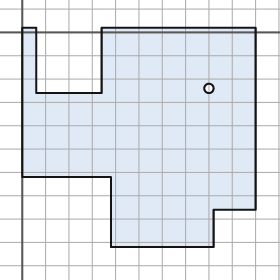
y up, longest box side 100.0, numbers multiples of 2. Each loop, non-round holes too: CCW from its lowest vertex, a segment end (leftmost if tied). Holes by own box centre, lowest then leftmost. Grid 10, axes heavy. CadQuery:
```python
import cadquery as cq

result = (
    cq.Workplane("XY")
    .moveTo(38.0, -92.0)
    .lineTo(82.0, -92.0)
    .lineTo(82.0, -76.0)
    .lineTo(100.0, -76.0)
    .lineTo(100.0, 2.0)
    .lineTo(34.0, 2.0)
    .lineTo(34.0, -26.0)
    .lineTo(6.0, -26.0)
    .lineTo(6.0, 2.0)
    .lineTo(0.0, 2.0)
    .lineTo(0.0, -62.0)
    .lineTo(38.0, -62.0)
    .close()
    .moveTo(80.0, -24.0)
    .circle(2.0)
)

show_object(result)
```